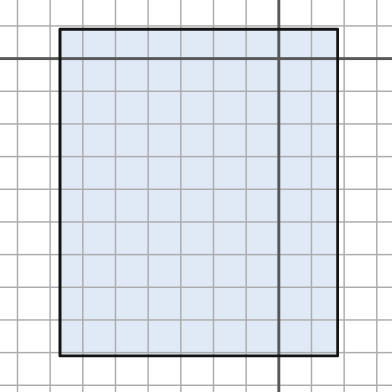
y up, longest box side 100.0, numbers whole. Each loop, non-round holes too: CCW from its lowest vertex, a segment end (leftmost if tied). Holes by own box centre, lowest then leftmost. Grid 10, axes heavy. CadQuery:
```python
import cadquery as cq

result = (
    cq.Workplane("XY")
    .moveTo(-67.0, -91.0)
    .lineTo(18.0, -91.0)
    .lineTo(18.0, 9.0)
    .lineTo(-67.0, 9.0)
    .close()
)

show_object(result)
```